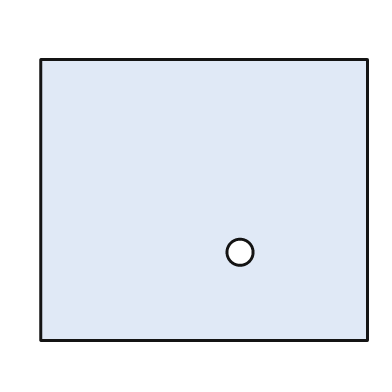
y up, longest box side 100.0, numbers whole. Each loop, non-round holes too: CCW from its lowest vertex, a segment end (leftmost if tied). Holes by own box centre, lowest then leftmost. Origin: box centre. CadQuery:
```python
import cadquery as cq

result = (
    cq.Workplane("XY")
    .moveTo(-50.0, -43.0)
    .lineTo(50.0, -43.0)
    .lineTo(50.0, 43.0)
    .lineTo(-50.0, 43.0)
    .close()
    .moveTo(11.0, -16.0)
    .circle(4.0)
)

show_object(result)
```